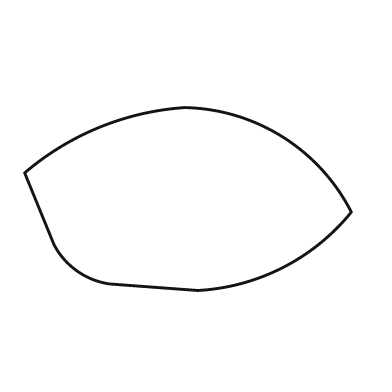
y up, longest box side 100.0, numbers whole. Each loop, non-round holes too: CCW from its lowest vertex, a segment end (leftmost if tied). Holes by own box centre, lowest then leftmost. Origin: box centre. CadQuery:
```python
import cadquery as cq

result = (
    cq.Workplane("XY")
    .moveTo(3.0, -28.0)
    .threePointArc((29.0, -21.0), (50.0, -4.0))
    .threePointArc((29.0, 19.0), (-1.0, 28.0))
    .threePointArc((-27.0, 22.0), (-50.0, 8.0))
    .lineTo(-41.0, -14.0)
    .threePointArc((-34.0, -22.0), (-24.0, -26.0))
    .close()
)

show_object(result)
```